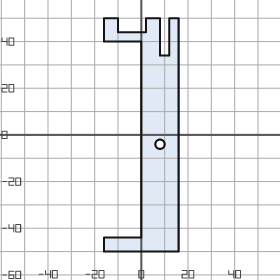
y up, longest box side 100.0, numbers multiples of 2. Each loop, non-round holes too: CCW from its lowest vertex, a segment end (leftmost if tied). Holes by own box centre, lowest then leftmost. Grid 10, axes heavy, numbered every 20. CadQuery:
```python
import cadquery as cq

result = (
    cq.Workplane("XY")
    .moveTo(-16.0, -50.0)
    .lineTo(16.0, -50.0)
    .lineTo(16.0, 50.0)
    .lineTo(12.0, 50.0)
    .lineTo(12.0, 34.0)
    .lineTo(8.0, 34.0)
    .lineTo(8.0, 50.0)
    .lineTo(2.0, 50.0)
    .lineTo(2.0, 44.0)
    .lineTo(-10.0, 44.0)
    .lineTo(-10.0, 50.0)
    .lineTo(-16.0, 50.0)
    .lineTo(-16.0, 40.0)
    .lineTo(0.0, 40.0)
    .lineTo(0.0, -44.0)
    .lineTo(-16.0, -44.0)
    .close()
    .moveTo(8.0, -4.0)
    .circle(2.0)
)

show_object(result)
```